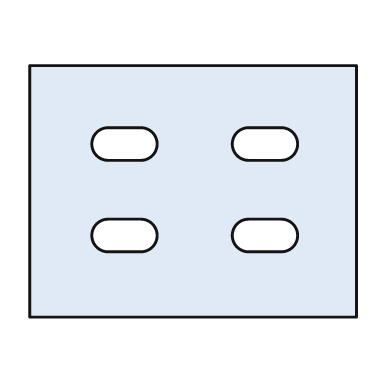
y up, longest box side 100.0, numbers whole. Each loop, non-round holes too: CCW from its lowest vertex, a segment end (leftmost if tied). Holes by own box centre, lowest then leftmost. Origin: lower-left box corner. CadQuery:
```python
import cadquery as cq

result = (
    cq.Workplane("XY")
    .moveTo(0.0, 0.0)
    .lineTo(100.0, 0.0)
    .lineTo(100.0, 77.0)
    .lineTo(0.0, 77.0)
    .close()
    .moveTo(24.0, 20.0)
    .lineTo(34.0, 20.0)
    .threePointArc((39.0, 25.0), (34.0, 30.0))
    .lineTo(24.0, 30.0)
    .threePointArc((19.0, 25.0), (24.0, 20.0))
    .close()
    .moveTo(67.0, 20.0)
    .lineTo(77.0, 20.0)
    .threePointArc((82.0, 25.0), (77.0, 30.0))
    .lineTo(67.0, 30.0)
    .threePointArc((62.0, 25.0), (67.0, 20.0))
    .close()
    .moveTo(24.0, 48.0)
    .lineTo(34.0, 48.0)
    .threePointArc((39.0, 53.0), (34.0, 58.0))
    .lineTo(24.0, 58.0)
    .threePointArc((19.0, 53.0), (24.0, 48.0))
    .close()
    .moveTo(67.0, 48.0)
    .lineTo(77.0, 48.0)
    .threePointArc((82.0, 53.0), (77.0, 58.0))
    .lineTo(67.0, 58.0)
    .threePointArc((62.0, 53.0), (67.0, 48.0))
    .close()
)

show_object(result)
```